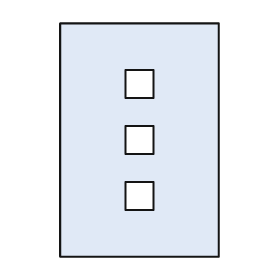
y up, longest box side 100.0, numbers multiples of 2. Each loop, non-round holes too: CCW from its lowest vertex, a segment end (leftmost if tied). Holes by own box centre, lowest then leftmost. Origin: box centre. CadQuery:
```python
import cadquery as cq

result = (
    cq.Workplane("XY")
    .moveTo(-34.0, -50.0)
    .lineTo(34.0, -50.0)
    .lineTo(34.0, 50.0)
    .lineTo(-34.0, 50.0)
    .close()
    .moveTo(-6.0, -30.0)
    .lineTo(6.0, -30.0)
    .lineTo(6.0, -18.0)
    .lineTo(-6.0, -18.0)
    .close()
    .moveTo(-6.0, -6.0)
    .lineTo(6.0, -6.0)
    .lineTo(6.0, 6.0)
    .lineTo(-6.0, 6.0)
    .close()
    .moveTo(-6.0, 18.0)
    .lineTo(6.0, 18.0)
    .lineTo(6.0, 30.0)
    .lineTo(-6.0, 30.0)
    .close()
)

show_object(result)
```